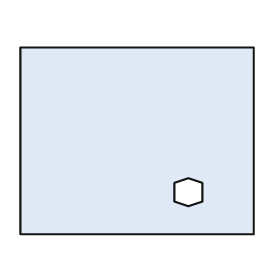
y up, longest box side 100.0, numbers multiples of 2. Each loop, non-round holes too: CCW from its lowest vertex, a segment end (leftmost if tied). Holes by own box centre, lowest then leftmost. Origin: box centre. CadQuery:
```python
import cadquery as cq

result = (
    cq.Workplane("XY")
    .moveTo(-50.0, -40.0)
    .lineTo(50.0, -40.0)
    .lineTo(50.0, 40.0)
    .lineTo(-50.0, 40.0)
    .close()
    .moveTo(22.0, -28.0)
    .lineTo(28.0, -26.0)
    .lineTo(28.0, -18.0)
    .lineTo(22.0, -16.0)
    .lineTo(16.0, -18.0)
    .lineTo(16.0, -26.0)
    .close()
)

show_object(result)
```